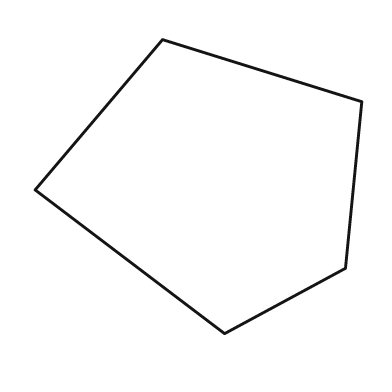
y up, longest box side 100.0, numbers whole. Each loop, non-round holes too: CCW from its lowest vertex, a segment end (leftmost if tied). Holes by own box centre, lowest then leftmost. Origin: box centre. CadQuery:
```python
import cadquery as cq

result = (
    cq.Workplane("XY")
    .moveTo(8.0, -45.0)
    .lineTo(45.0, -25.0)
    .lineTo(50.0, 26.0)
    .lineTo(-11.0, 45.0)
    .lineTo(-50.0, -1.0)
    .close()
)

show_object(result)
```